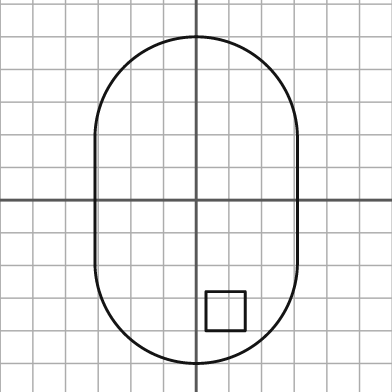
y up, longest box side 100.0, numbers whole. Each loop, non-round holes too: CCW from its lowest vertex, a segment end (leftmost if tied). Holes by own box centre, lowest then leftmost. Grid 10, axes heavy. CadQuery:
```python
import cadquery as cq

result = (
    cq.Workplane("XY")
    .moveTo(-31.0, -19.0)
    .threePointArc((0.0, -50.0), (31.0, -19.0))
    .lineTo(31.0, 19.0)
    .threePointArc((0.0, 50.0), (-31.0, 19.0))
    .close()
    .moveTo(3.0, -40.0)
    .lineTo(15.0, -40.0)
    .lineTo(15.0, -28.0)
    .lineTo(3.0, -28.0)
    .close()
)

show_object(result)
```